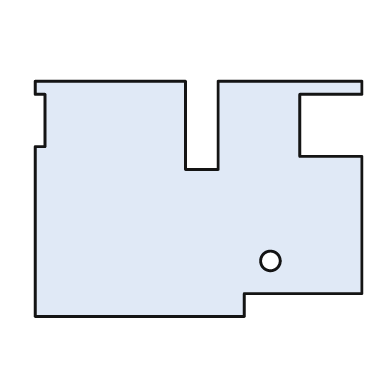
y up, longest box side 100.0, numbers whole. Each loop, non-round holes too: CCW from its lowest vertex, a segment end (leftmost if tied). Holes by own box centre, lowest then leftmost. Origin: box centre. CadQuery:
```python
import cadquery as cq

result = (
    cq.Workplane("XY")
    .moveTo(-50.0, -36.0)
    .lineTo(14.0, -36.0)
    .lineTo(14.0, -29.0)
    .lineTo(50.0, -29.0)
    .lineTo(50.0, 13.0)
    .lineTo(31.0, 13.0)
    .lineTo(31.0, 32.0)
    .lineTo(50.0, 32.0)
    .lineTo(50.0, 36.0)
    .lineTo(6.0, 36.0)
    .lineTo(6.0, 9.0)
    .lineTo(-4.0, 9.0)
    .lineTo(-4.0, 36.0)
    .lineTo(-50.0, 36.0)
    .lineTo(-50.0, 32.0)
    .lineTo(-47.0, 32.0)
    .lineTo(-47.0, 16.0)
    .lineTo(-50.0, 16.0)
    .close()
    .moveTo(22.0, -19.0)
    .circle(3.0)
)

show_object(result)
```